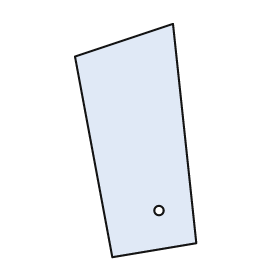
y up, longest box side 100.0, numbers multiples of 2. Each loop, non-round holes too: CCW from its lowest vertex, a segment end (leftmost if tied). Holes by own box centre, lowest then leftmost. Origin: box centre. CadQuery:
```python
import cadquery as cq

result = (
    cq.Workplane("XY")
    .moveTo(-10.0, -50.0)
    .lineTo(26.0, -44.0)
    .lineTo(16.0, 50.0)
    .lineTo(-26.0, 36.0)
    .close()
    .moveTo(10.0, -30.0)
    .circle(2.0)
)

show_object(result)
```